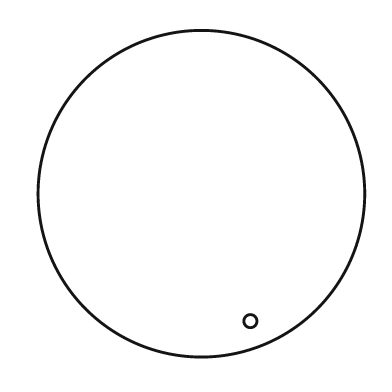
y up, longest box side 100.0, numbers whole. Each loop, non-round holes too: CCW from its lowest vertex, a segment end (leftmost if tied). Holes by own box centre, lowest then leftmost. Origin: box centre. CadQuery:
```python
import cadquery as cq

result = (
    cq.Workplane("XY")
    .moveTo(0.0, 0.0)
    .circle(50.0)
    .moveTo(15.0, -39.0)
    .circle(2.0)
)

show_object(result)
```